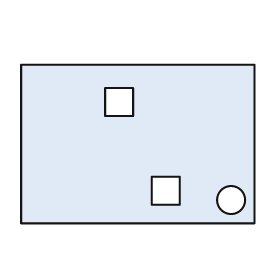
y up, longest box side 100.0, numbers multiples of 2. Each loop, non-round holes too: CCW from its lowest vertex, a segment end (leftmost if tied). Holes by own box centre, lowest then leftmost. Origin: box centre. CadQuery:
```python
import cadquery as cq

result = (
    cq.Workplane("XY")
    .moveTo(-50.0, -34.0)
    .lineTo(50.0, -34.0)
    .lineTo(50.0, 34.0)
    .lineTo(-50.0, 34.0)
    .close()
    .moveTo(40.0, -24.0)
    .circle(6.0)
    .moveTo(6.0, -26.0)
    .lineTo(18.0, -26.0)
    .lineTo(18.0, -14.0)
    .lineTo(6.0, -14.0)
    .close()
    .moveTo(-14.0, 12.0)
    .lineTo(-2.0, 12.0)
    .lineTo(-2.0, 24.0)
    .lineTo(-14.0, 24.0)
    .close()
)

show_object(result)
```